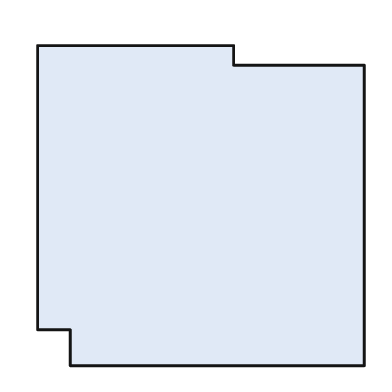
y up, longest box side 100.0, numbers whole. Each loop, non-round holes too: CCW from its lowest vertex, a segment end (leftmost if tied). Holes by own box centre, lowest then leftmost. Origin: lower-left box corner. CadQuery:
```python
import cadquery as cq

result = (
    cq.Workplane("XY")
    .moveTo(10.0, 0.0)
    .lineTo(100.0, 0.0)
    .lineTo(100.0, 92.0)
    .lineTo(60.0, 92.0)
    .lineTo(60.0, 98.0)
    .lineTo(0.0, 98.0)
    .lineTo(0.0, 11.0)
    .lineTo(10.0, 11.0)
    .close()
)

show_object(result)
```